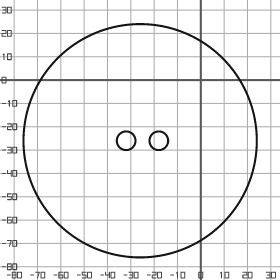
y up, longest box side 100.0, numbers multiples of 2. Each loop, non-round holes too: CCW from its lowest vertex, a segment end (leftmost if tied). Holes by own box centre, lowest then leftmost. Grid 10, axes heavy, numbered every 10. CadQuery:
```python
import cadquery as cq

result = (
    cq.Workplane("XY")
    .moveTo(-26.0, -26.0)
    .circle(50.0)
    .moveTo(-32.0, -26.0)
    .circle(4.0)
    .moveTo(-18.0, -26.0)
    .circle(4.0)
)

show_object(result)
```